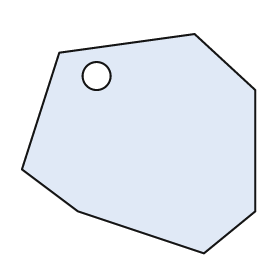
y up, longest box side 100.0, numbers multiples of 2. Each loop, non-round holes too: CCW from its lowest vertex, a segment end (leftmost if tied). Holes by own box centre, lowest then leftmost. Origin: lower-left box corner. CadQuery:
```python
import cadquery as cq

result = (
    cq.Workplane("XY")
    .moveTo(78.0, 0.0)
    .lineTo(100.0, 18.0)
    .lineTo(100.0, 70.0)
    .lineTo(74.0, 94.0)
    .lineTo(16.0, 86.0)
    .lineTo(0.0, 36.0)
    .lineTo(24.0, 18.0)
    .close()
    .moveTo(32.0, 76.0)
    .circle(6.0)
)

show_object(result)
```